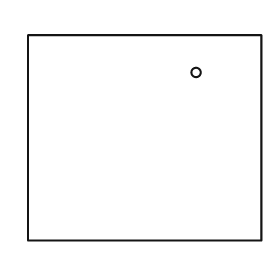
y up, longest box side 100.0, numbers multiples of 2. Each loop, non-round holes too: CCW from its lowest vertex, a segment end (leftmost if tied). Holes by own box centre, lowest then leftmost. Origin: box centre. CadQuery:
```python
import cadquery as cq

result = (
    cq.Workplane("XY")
    .moveTo(-50.0, -44.0)
    .lineTo(50.0, -44.0)
    .lineTo(50.0, 44.0)
    .lineTo(-50.0, 44.0)
    .close()
    .moveTo(22.0, 28.0)
    .circle(2.0)
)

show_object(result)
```